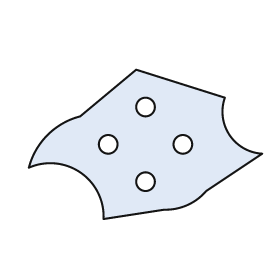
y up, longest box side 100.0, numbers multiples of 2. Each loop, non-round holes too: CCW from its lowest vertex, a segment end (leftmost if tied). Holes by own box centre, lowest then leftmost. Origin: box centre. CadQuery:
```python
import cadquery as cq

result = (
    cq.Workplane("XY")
    .moveTo(-18.0, -32.0)
    .lineTo(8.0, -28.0)
    .threePointArc((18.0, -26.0), (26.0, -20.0))
    .lineTo(50.0, -4.0)
    .threePointArc((36.0, 4.0), (34.0, 20.0))
    .lineTo(-4.0, 32.0)
    .lineTo(-28.0, 12.0)
    .threePointArc((-42.0, 4.0), (-50.0, -10.0))
    .threePointArc((-28.0, -12.0), (-18.0, -32.0))
    .close()
    .moveTo(0.0, -16.0)
    .circle(4.0)
    .moveTo(-16.0, 0.0)
    .circle(4.0)
    .moveTo(16.0, 0.0)
    .circle(4.0)
    .moveTo(0.0, 16.0)
    .circle(4.0)
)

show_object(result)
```